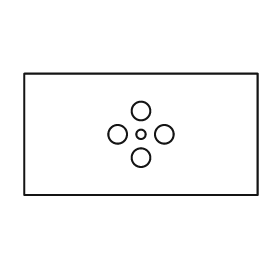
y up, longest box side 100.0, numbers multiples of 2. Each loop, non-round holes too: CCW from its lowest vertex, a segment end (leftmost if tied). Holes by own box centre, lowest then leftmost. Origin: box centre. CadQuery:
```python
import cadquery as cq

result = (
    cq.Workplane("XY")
    .moveTo(-50.0, -26.0)
    .lineTo(50.0, -26.0)
    .lineTo(50.0, 26.0)
    .lineTo(-50.0, 26.0)
    .close()
    .moveTo(0.0, -10.0)
    .circle(4.0)
    .moveTo(-10.0, 0.0)
    .circle(4.0)
    .moveTo(0.0, 0.0)
    .circle(2.0)
    .moveTo(10.0, 0.0)
    .circle(4.0)
    .moveTo(0.0, 10.0)
    .circle(4.0)
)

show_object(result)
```